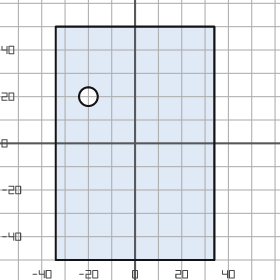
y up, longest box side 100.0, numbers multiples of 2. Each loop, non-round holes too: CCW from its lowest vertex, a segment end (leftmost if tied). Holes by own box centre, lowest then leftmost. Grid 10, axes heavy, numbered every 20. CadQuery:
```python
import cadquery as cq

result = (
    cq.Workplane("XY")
    .moveTo(-34.0, -50.0)
    .lineTo(34.0, -50.0)
    .lineTo(34.0, 50.0)
    .lineTo(-34.0, 50.0)
    .close()
    .moveTo(-20.0, 20.0)
    .circle(4.0)
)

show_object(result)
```